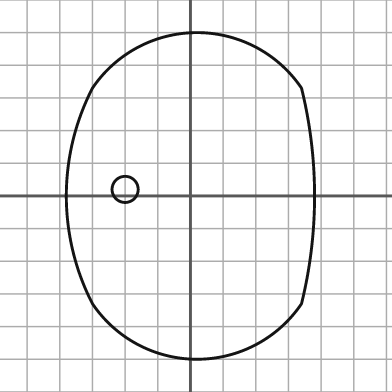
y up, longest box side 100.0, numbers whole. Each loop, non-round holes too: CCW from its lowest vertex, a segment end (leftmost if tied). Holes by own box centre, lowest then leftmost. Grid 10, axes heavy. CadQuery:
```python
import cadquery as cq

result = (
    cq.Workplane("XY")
    .moveTo(-30.0, -33.0)
    .threePointArc((2.0, -50.0), (34.0, -33.0))
    .threePointArc((38.0, 0.0), (34.0, 33.0))
    .threePointArc((2.0, 50.0), (-30.0, 33.0))
    .threePointArc((-38.0, 0.0), (-30.0, -33.0))
    .close()
    .moveTo(-20.0, 2.0)
    .circle(4.0)
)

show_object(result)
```